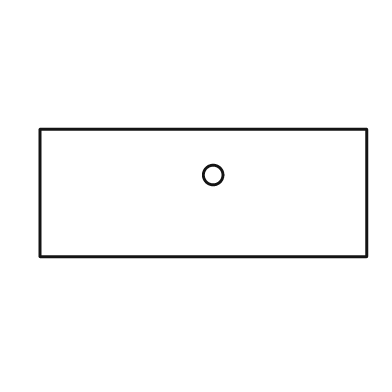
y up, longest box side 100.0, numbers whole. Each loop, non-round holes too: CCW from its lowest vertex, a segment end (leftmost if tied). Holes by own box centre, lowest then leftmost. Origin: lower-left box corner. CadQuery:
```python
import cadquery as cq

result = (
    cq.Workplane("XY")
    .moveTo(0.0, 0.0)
    .lineTo(100.0, 0.0)
    .lineTo(100.0, 39.0)
    .lineTo(0.0, 39.0)
    .close()
    .moveTo(53.0, 25.0)
    .circle(3.0)
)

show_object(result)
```